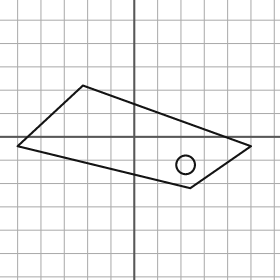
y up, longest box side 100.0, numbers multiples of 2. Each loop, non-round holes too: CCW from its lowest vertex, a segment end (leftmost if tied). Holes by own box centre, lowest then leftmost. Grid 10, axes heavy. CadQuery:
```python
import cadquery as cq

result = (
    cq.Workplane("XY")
    .moveTo(24.0, -22.0)
    .lineTo(50.0, -4.0)
    .lineTo(-22.0, 22.0)
    .lineTo(-50.0, -4.0)
    .close()
    .moveTo(22.0, -12.0)
    .circle(4.0)
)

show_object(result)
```